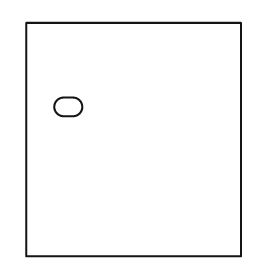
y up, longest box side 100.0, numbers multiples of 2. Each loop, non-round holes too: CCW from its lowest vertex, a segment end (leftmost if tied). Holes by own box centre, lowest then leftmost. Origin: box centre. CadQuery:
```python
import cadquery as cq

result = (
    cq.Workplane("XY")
    .moveTo(-46.0, -50.0)
    .lineTo(46.0, -50.0)
    .lineTo(46.0, 50.0)
    .lineTo(-46.0, 50.0)
    .close()
    .moveTo(-30.0, 10.0)
    .lineTo(-26.0, 10.0)
    .threePointArc((-22.0, 14.0), (-26.0, 18.0))
    .lineTo(-30.0, 18.0)
    .threePointArc((-34.0, 14.0), (-30.0, 10.0))
    .close()
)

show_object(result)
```